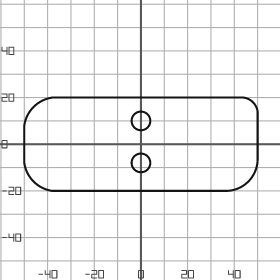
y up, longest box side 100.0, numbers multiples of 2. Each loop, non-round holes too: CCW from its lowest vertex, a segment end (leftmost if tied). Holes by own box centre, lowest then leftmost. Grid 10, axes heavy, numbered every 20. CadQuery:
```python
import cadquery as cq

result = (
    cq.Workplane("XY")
    .moveTo(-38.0, -20.0)
    .lineTo(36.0, -20.0)
    .threePointArc((46.0, -16.0), (50.0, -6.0))
    .lineTo(50.0, 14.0)
    .threePointArc((48.0, 18.0), (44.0, 20.0))
    .lineTo(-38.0, 20.0)
    .threePointArc((-46.0, 16.0), (-50.0, 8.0))
    .lineTo(-50.0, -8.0)
    .threePointArc((-46.0, -16.0), (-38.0, -20.0))
    .close()
    .moveTo(0.0, -8.0)
    .circle(4.0)
    .moveTo(0.0, 10.0)
    .circle(4.0)
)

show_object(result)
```